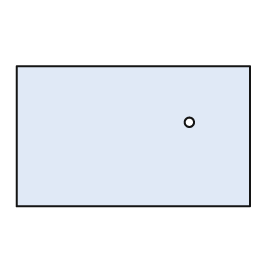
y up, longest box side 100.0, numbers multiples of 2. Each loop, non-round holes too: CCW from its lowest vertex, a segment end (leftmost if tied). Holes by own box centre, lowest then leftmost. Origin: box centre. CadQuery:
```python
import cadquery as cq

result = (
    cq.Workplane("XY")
    .moveTo(-50.0, -30.0)
    .lineTo(50.0, -30.0)
    .lineTo(50.0, 30.0)
    .lineTo(-50.0, 30.0)
    .close()
    .moveTo(24.0, 6.0)
    .circle(2.0)
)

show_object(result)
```